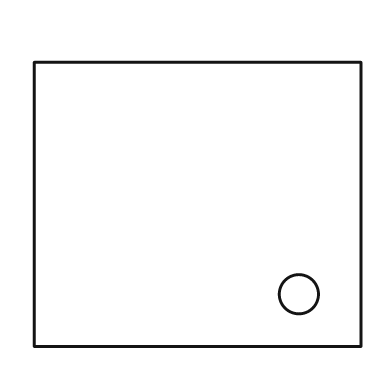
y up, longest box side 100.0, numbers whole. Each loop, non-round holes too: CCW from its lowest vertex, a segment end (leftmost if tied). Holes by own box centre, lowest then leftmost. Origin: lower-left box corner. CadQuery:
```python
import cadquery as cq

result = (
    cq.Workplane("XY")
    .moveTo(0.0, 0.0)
    .lineTo(100.0, 0.0)
    .lineTo(100.0, 87.0)
    .lineTo(0.0, 87.0)
    .close()
    .moveTo(81.0, 16.0)
    .circle(6.0)
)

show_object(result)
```